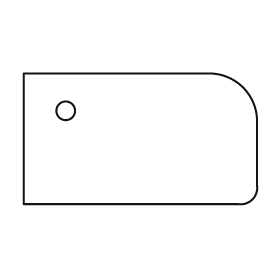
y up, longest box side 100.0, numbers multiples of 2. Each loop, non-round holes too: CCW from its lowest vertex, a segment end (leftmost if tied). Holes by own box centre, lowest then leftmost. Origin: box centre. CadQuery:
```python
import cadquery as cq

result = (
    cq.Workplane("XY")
    .moveTo(-50.0, -28.0)
    .lineTo(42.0, -28.0)
    .threePointArc((48.0, -26.0), (50.0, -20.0))
    .lineTo(50.0, 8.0)
    .threePointArc((44.0, 22.0), (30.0, 28.0))
    .lineTo(-50.0, 28.0)
    .close()
    .moveTo(-32.0, 12.0)
    .circle(4.0)
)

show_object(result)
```